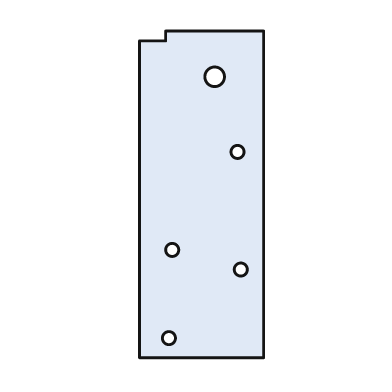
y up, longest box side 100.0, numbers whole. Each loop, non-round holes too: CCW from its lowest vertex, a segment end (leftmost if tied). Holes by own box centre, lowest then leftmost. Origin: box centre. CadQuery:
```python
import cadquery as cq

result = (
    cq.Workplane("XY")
    .moveTo(-19.0, -50.0)
    .lineTo(19.0, -50.0)
    .lineTo(19.0, 50.0)
    .lineTo(-11.0, 50.0)
    .lineTo(-11.0, 47.0)
    .lineTo(-19.0, 47.0)
    .close()
    .moveTo(-10.0, -44.0)
    .circle(2.0)
    .moveTo(12.0, -23.0)
    .circle(2.0)
    .moveTo(-9.0, -17.0)
    .circle(2.0)
    .moveTo(11.0, 13.0)
    .circle(2.0)
    .moveTo(4.0, 36.0)
    .circle(3.0)
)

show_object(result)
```